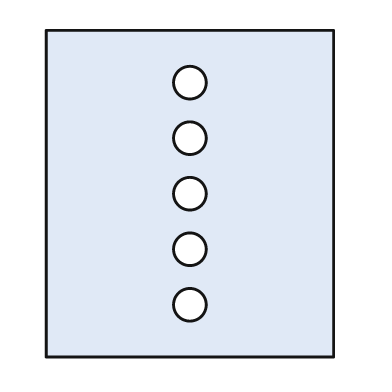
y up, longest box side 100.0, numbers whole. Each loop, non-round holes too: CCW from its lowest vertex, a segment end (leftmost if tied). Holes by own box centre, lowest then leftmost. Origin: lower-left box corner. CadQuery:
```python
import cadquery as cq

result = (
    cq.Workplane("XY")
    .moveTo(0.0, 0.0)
    .lineTo(88.0, 0.0)
    .lineTo(88.0, 100.0)
    .lineTo(0.0, 100.0)
    .close()
    .moveTo(44.0, 16.0)
    .circle(5.0)
    .moveTo(44.0, 33.0)
    .circle(5.0)
    .moveTo(44.0, 50.0)
    .circle(5.0)
    .moveTo(44.0, 67.0)
    .circle(5.0)
    .moveTo(44.0, 84.0)
    .circle(5.0)
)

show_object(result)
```